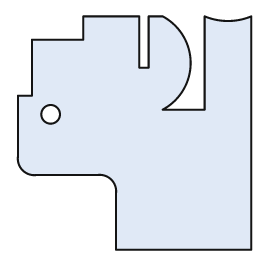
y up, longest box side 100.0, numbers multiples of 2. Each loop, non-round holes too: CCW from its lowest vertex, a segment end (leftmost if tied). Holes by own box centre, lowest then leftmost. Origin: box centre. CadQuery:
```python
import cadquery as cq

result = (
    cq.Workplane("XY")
    .moveTo(-8.0, -50.0)
    .lineTo(50.0, -50.0)
    .lineTo(50.0, 50.0)
    .threePointArc((40.0, 48.0), (30.0, 50.0))
    .lineTo(30.0, 10.0)
    .lineTo(12.0, 10.0)
    .threePointArc((24.0, 30.0), (12.0, 50.0))
    .lineTo(6.0, 50.0)
    .lineTo(6.0, 28.0)
    .lineTo(2.0, 28.0)
    .lineTo(2.0, 50.0)
    .lineTo(-22.0, 50.0)
    .lineTo(-22.0, 40.0)
    .lineTo(-44.0, 40.0)
    .lineTo(-44.0, 16.0)
    .lineTo(-50.0, 16.0)
    .lineTo(-50.0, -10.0)
    .threePointArc((-48.0, -16.0), (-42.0, -18.0))
    .lineTo(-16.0, -18.0)
    .threePointArc((-10.0, -20.0), (-8.0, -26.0))
    .close()
    .moveTo(-36.0, 8.0)
    .circle(4.0)
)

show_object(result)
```